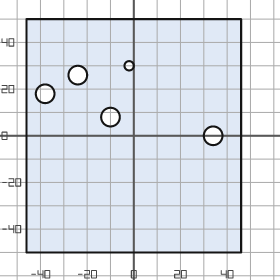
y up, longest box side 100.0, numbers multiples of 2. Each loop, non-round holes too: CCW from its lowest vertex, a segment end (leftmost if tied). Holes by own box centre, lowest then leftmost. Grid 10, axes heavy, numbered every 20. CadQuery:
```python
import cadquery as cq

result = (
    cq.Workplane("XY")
    .moveTo(-46.0, -50.0)
    .lineTo(46.0, -50.0)
    .lineTo(46.0, 50.0)
    .lineTo(-46.0, 50.0)
    .close()
    .moveTo(34.0, 0.0)
    .circle(4.0)
    .moveTo(-10.0, 8.0)
    .circle(4.0)
    .moveTo(-38.0, 18.0)
    .circle(4.0)
    .moveTo(-24.0, 26.0)
    .circle(4.0)
    .moveTo(-2.0, 30.0)
    .circle(2.0)
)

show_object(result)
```